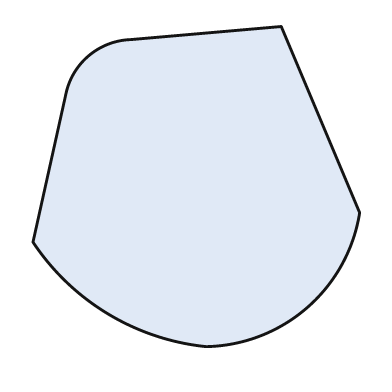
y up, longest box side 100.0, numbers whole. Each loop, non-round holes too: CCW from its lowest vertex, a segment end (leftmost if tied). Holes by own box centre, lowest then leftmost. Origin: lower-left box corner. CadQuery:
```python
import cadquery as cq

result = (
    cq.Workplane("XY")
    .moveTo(53.0, 0.0)
    .threePointArc((84.0, 12.0), (100.0, 41.0))
    .lineTo(76.0, 98.0)
    .lineTo(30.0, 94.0)
    .threePointArc((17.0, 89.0), (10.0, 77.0))
    .lineTo(0.0, 32.0)
    .threePointArc((23.0, 10.0), (53.0, 0.0))
    .close()
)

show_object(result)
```